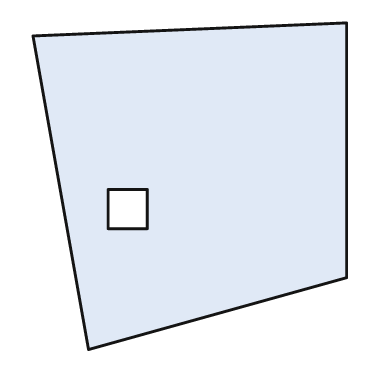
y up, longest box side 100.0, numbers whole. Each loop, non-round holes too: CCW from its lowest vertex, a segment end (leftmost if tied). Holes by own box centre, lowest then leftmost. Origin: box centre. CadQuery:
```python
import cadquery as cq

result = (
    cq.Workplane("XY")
    .moveTo(-31.0, -50.0)
    .lineTo(48.0, -28.0)
    .lineTo(48.0, 50.0)
    .lineTo(-48.0, 46.0)
    .close()
    .moveTo(-25.0, -13.0)
    .lineTo(-13.0, -13.0)
    .lineTo(-13.0, -1.0)
    .lineTo(-25.0, -1.0)
    .close()
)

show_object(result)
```